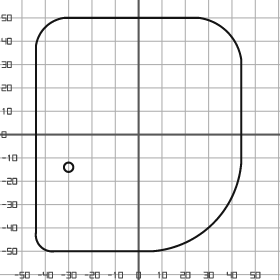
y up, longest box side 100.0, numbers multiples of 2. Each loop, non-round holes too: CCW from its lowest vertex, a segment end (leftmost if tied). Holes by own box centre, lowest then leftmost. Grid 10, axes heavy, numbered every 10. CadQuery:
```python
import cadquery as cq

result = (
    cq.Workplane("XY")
    .moveTo(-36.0, -50.0)
    .lineTo(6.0, -50.0)
    .threePointArc((32.0, -38.0), (44.0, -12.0))
    .lineTo(44.0, 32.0)
    .threePointArc((38.0, 44.0), (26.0, 50.0))
    .lineTo(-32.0, 50.0)
    .threePointArc((-40.0, 46.0), (-44.0, 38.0))
    .lineTo(-44.0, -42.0)
    .threePointArc((-42.0, -48.0), (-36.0, -50.0))
    .close()
    .moveTo(-30.0, -14.0)
    .circle(2.0)
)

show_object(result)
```